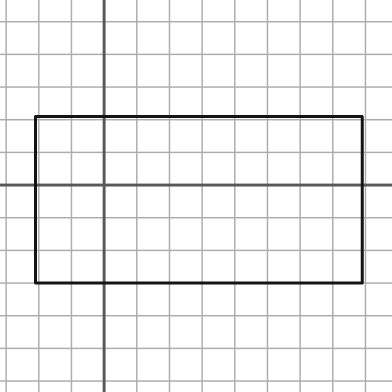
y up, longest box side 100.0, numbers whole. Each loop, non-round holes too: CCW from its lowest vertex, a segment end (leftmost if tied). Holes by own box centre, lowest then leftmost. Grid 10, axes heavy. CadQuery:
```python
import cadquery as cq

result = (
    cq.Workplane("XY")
    .moveTo(-21.0, -30.0)
    .lineTo(79.0, -30.0)
    .lineTo(79.0, 21.0)
    .lineTo(-21.0, 21.0)
    .close()
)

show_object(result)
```